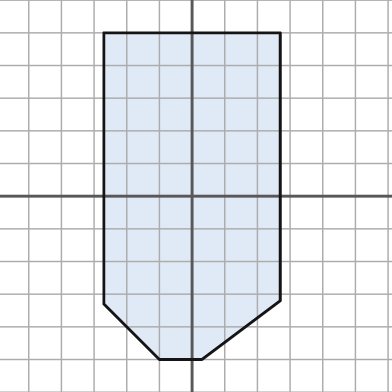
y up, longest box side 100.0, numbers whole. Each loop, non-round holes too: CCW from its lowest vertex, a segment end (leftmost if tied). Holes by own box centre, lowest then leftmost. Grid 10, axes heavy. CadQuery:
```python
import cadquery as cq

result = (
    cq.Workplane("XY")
    .moveTo(-10.0, -50.0)
    .lineTo(3.0, -50.0)
    .lineTo(27.0, -32.0)
    .lineTo(27.0, 50.0)
    .lineTo(-27.0, 50.0)
    .lineTo(-27.0, -33.0)
    .close()
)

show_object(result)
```